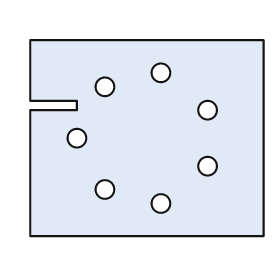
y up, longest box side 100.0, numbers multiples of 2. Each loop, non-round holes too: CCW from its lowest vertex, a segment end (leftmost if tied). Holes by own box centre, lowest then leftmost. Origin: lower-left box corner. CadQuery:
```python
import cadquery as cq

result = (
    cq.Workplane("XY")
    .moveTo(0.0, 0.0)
    .lineTo(100.0, 0.0)
    .lineTo(100.0, 84.0)
    .lineTo(0.0, 84.0)
    .lineTo(0.0, 58.0)
    .lineTo(20.0, 58.0)
    .lineTo(20.0, 54.0)
    .lineTo(0.0, 54.0)
    .close()
    .moveTo(56.0, 14.0)
    .circle(4.0)
    .moveTo(32.0, 20.0)
    .circle(4.0)
    .moveTo(76.0, 30.0)
    .circle(4.0)
    .moveTo(20.0, 42.0)
    .circle(4.0)
    .moveTo(76.0, 54.0)
    .circle(4.0)
    .moveTo(32.0, 64.0)
    .circle(4.0)
    .moveTo(56.0, 70.0)
    .circle(4.0)
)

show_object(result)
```